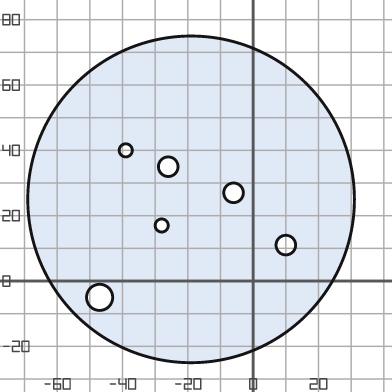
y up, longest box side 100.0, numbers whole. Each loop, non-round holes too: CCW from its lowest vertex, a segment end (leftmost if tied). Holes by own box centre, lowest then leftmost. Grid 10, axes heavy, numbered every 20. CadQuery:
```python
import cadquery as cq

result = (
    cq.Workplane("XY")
    .moveTo(-19.0, 25.0)
    .circle(50.0)
    .moveTo(-47.0, -5.0)
    .circle(4.0)
    .moveTo(10.0, 11.0)
    .circle(3.0)
    .moveTo(-28.0, 17.0)
    .circle(2.0)
    .moveTo(-6.0, 27.0)
    .circle(3.0)
    .moveTo(-26.0, 35.0)
    .circle(3.0)
    .moveTo(-39.0, 40.0)
    .circle(2.0)
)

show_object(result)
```